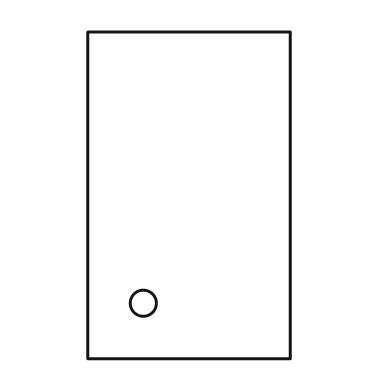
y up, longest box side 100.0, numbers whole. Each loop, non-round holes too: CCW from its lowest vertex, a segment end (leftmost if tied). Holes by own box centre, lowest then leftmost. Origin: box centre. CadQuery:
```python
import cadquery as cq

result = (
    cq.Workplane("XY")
    .moveTo(-31.0, -50.0)
    .lineTo(31.0, -50.0)
    .lineTo(31.0, 50.0)
    .lineTo(-31.0, 50.0)
    .close()
    .moveTo(-14.0, -33.0)
    .circle(4.0)
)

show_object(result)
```